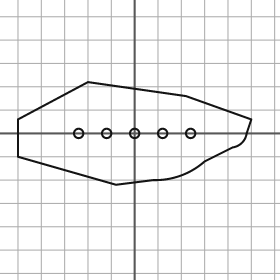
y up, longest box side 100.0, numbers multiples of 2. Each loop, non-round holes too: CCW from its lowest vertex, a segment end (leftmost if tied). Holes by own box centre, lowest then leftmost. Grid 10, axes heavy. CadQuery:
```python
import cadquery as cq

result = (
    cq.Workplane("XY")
    .moveTo(-8.0, -22.0)
    .lineTo(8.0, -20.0)
    .threePointArc((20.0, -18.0), (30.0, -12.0))
    .lineTo(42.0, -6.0)
    .threePointArc((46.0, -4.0), (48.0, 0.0))
    .lineTo(50.0, 6.0)
    .lineTo(22.0, 16.0)
    .lineTo(-20.0, 22.0)
    .lineTo(-50.0, 6.0)
    .lineTo(-50.0, -10.0)
    .close()
    .moveTo(-24.0, 0.0)
    .circle(2.0)
    .moveTo(-12.0, 0.0)
    .circle(2.0)
    .moveTo(0.0, 0.0)
    .circle(2.0)
    .moveTo(12.0, 0.0)
    .circle(2.0)
    .moveTo(24.0, 0.0)
    .circle(2.0)
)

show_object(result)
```